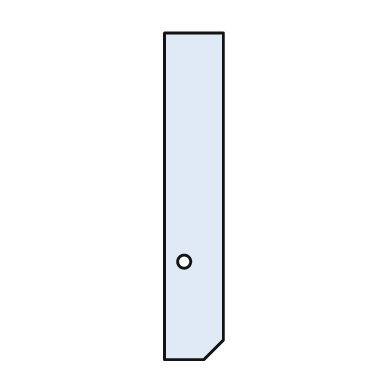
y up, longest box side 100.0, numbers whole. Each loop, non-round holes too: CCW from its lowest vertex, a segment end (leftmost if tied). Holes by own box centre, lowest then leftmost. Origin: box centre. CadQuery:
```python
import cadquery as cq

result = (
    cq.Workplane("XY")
    .moveTo(-9.0, -50.0)
    .lineTo(3.0, -50.0)
    .lineTo(9.0, -44.0)
    .lineTo(9.0, 50.0)
    .lineTo(-9.0, 50.0)
    .close()
    .moveTo(-3.0, -20.0)
    .circle(2.0)
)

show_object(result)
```